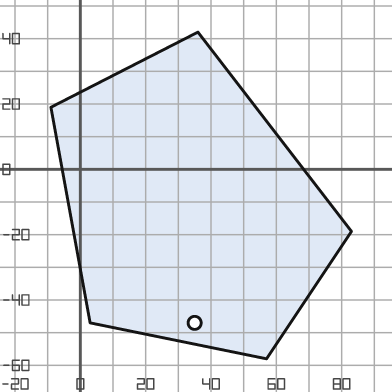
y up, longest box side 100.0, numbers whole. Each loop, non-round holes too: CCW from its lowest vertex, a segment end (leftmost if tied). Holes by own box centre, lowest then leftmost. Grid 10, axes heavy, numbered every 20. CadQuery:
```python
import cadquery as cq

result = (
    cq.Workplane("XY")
    .moveTo(57.0, -58.0)
    .lineTo(83.0, -19.0)
    .lineTo(36.0, 42.0)
    .lineTo(-9.0, 19.0)
    .lineTo(3.0, -47.0)
    .close()
    .moveTo(35.0, -47.0)
    .circle(2.0)
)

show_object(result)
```